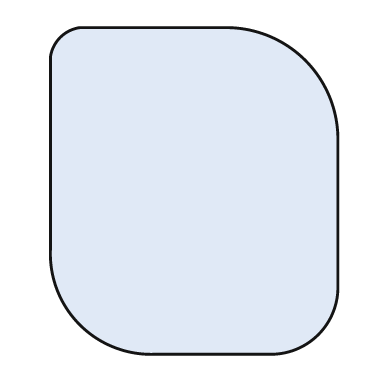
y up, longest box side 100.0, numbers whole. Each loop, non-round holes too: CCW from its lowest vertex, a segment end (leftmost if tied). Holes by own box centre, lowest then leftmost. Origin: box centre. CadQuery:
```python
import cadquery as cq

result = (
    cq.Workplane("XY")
    .moveTo(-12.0, -50.0)
    .lineTo(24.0, -50.0)
    .threePointArc((38.0, -44.0), (44.0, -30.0))
    .lineTo(44.0, 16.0)
    .threePointArc((34.0, 40.0), (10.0, 50.0))
    .lineTo(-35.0, 50.0)
    .threePointArc((-41.0, 47.0), (-44.0, 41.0))
    .lineTo(-44.0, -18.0)
    .threePointArc((-35.0, -41.0), (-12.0, -50.0))
    .close()
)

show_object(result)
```